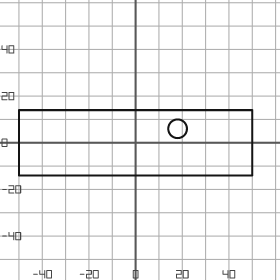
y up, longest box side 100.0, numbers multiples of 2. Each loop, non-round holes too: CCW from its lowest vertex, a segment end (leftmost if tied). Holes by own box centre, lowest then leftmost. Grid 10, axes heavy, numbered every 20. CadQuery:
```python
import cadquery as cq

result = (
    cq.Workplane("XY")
    .moveTo(-50.0, -14.0)
    .lineTo(50.0, -14.0)
    .lineTo(50.0, 14.0)
    .lineTo(-50.0, 14.0)
    .close()
    .moveTo(18.0, 6.0)
    .circle(4.0)
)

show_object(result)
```